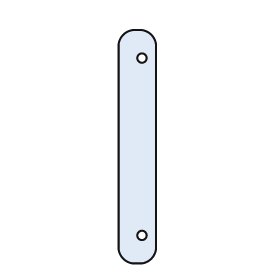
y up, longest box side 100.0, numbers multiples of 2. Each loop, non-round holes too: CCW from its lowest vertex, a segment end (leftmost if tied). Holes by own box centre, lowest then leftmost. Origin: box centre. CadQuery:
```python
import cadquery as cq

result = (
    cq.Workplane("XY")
    .moveTo(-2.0, -50.0)
    .lineTo(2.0, -50.0)
    .threePointArc((6.0, -48.0), (8.0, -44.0))
    .lineTo(8.0, 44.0)
    .threePointArc((6.0, 48.0), (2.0, 50.0))
    .lineTo(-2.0, 50.0)
    .threePointArc((-6.0, 48.0), (-8.0, 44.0))
    .lineTo(-8.0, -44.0)
    .threePointArc((-6.0, -48.0), (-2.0, -50.0))
    .close()
    .moveTo(2.0, -38.0)
    .circle(2.0)
    .moveTo(2.0, 38.0)
    .circle(2.0)
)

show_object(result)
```